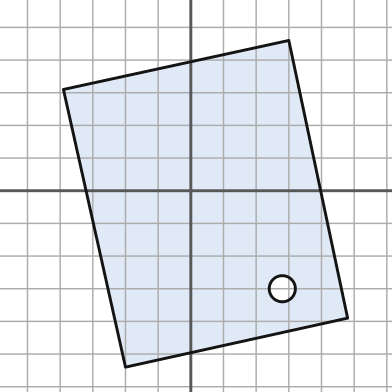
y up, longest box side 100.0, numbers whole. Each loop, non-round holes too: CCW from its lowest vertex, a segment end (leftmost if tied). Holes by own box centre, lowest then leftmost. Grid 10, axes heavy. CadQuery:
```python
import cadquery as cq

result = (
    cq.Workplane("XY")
    .moveTo(-20.0, -54.0)
    .lineTo(48.0, -39.0)
    .lineTo(30.0, 46.0)
    .lineTo(-39.0, 31.0)
    .close()
    .moveTo(28.0, -30.0)
    .circle(4.0)
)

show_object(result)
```